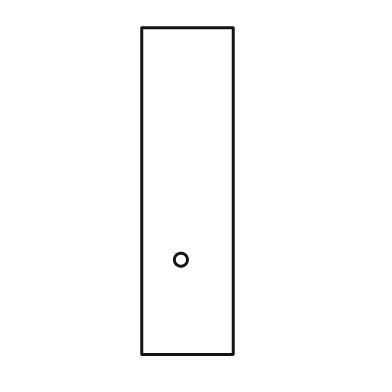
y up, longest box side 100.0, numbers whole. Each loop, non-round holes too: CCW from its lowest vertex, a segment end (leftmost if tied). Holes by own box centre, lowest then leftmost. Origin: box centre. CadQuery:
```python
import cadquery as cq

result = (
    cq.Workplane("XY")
    .moveTo(-14.0, -50.0)
    .lineTo(14.0, -50.0)
    .lineTo(14.0, 50.0)
    .lineTo(-14.0, 50.0)
    .close()
    .moveTo(-2.0, -21.0)
    .circle(2.0)
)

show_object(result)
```